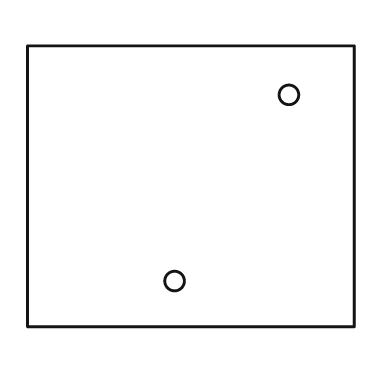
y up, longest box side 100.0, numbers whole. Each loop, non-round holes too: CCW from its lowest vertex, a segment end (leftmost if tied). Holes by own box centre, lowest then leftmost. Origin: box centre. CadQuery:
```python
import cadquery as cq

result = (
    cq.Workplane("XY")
    .moveTo(-50.0, -43.0)
    .lineTo(50.0, -43.0)
    .lineTo(50.0, 43.0)
    .lineTo(-50.0, 43.0)
    .close()
    .moveTo(-5.0, -29.0)
    .circle(3.0)
    .moveTo(30.0, 28.0)
    .circle(3.0)
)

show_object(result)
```